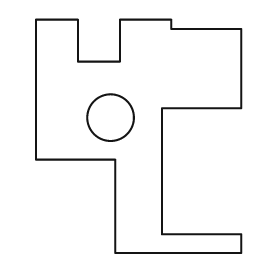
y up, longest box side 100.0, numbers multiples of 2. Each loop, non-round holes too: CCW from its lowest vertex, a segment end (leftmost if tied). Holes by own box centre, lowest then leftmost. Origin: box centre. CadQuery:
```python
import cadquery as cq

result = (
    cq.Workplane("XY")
    .moveTo(-10.0, -50.0)
    .lineTo(44.0, -50.0)
    .lineTo(44.0, -42.0)
    .lineTo(10.0, -42.0)
    .lineTo(10.0, 12.0)
    .lineTo(44.0, 12.0)
    .lineTo(44.0, 46.0)
    .lineTo(14.0, 46.0)
    .lineTo(14.0, 50.0)
    .lineTo(-8.0, 50.0)
    .lineTo(-8.0, 32.0)
    .lineTo(-26.0, 32.0)
    .lineTo(-26.0, 50.0)
    .lineTo(-44.0, 50.0)
    .lineTo(-44.0, -10.0)
    .lineTo(-10.0, -10.0)
    .close()
    .moveTo(-12.0, 8.0)
    .circle(10.0)
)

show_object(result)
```